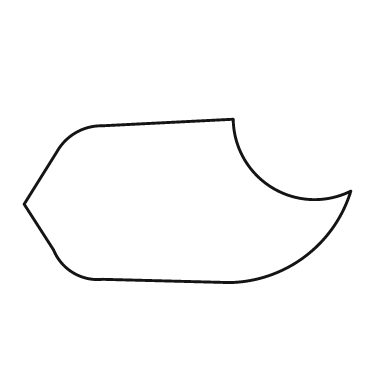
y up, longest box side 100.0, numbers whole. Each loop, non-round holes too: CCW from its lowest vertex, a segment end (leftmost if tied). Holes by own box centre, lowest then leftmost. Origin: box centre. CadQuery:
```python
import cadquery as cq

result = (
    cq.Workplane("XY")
    .moveTo(13.0, -25.0)
    .threePointArc((36.0, -17.0), (50.0, 3.0))
    .threePointArc((26.0, 4.0), (14.0, 25.0))
    .lineTo(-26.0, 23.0)
    .threePointArc((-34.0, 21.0), (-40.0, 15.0))
    .lineTo(-50.0, -1.0)
    .lineTo(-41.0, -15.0)
    .threePointArc((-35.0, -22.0), (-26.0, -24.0))
    .close()
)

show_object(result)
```